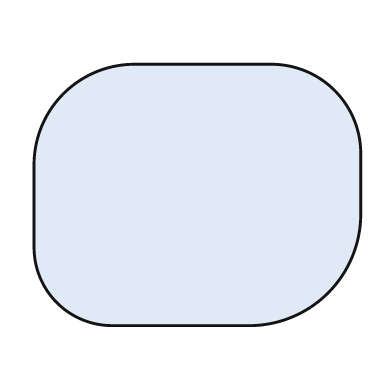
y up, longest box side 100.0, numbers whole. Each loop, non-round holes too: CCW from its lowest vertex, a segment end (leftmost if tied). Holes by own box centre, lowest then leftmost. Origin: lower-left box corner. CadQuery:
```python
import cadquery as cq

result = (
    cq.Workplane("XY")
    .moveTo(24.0, 0.0)
    .lineTo(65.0, 0.0)
    .threePointArc((90.0, 10.0), (100.0, 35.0))
    .lineTo(100.0, 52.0)
    .threePointArc((92.0, 72.0), (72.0, 80.0))
    .lineTo(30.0, 80.0)
    .threePointArc((9.0, 71.0), (0.0, 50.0))
    .lineTo(0.0, 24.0)
    .threePointArc((7.0, 7.0), (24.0, 0.0))
    .close()
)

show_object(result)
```